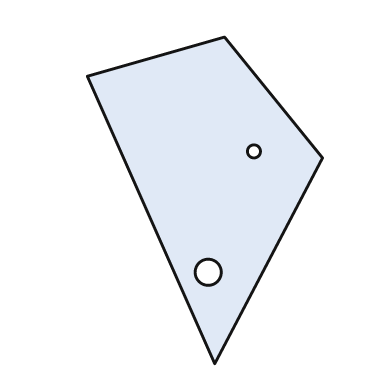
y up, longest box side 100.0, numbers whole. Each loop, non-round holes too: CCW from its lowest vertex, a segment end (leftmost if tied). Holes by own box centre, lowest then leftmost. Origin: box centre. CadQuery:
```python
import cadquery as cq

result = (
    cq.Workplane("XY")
    .moveTo(3.0, -50.0)
    .lineTo(36.0, 13.0)
    .lineTo(6.0, 50.0)
    .lineTo(-36.0, 38.0)
    .close()
    .moveTo(1.0, -22.0)
    .circle(4.0)
    .moveTo(15.0, 15.0)
    .circle(2.0)
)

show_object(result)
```